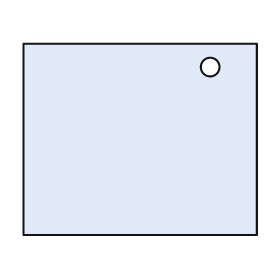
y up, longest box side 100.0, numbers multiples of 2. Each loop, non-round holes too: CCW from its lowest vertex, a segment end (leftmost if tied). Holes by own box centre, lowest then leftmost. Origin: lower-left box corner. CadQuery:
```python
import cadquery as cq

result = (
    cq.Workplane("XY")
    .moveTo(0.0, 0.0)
    .lineTo(100.0, 0.0)
    .lineTo(100.0, 82.0)
    .lineTo(0.0, 82.0)
    .close()
    .moveTo(80.0, 72.0)
    .circle(4.0)
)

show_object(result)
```